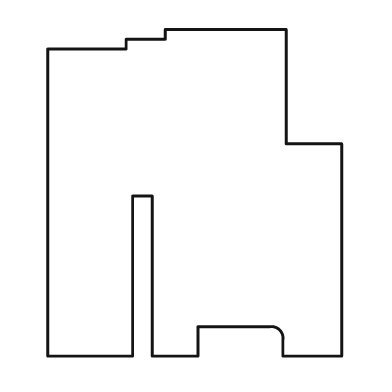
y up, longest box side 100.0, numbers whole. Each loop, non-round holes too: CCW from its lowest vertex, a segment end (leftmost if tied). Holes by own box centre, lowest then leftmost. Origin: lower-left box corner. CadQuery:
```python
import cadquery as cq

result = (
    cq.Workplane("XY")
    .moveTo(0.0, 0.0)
    .lineTo(26.0, 0.0)
    .lineTo(26.0, 49.0)
    .lineTo(32.0, 49.0)
    .lineTo(32.0, 0.0)
    .lineTo(46.0, 0.0)
    .lineTo(46.0, 9.0)
    .lineTo(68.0, 9.0)
    .threePointArc((71.0, 8.0), (72.0, 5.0))
    .lineTo(72.0, 0.0)
    .lineTo(90.0, 0.0)
    .lineTo(90.0, 65.0)
    .lineTo(73.0, 65.0)
    .lineTo(73.0, 100.0)
    .lineTo(36.0, 100.0)
    .lineTo(36.0, 97.0)
    .lineTo(24.0, 97.0)
    .lineTo(24.0, 94.0)
    .lineTo(0.0, 94.0)
    .close()
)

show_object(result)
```